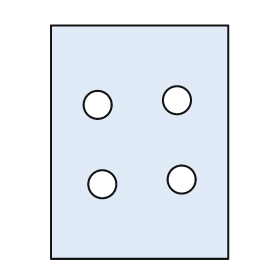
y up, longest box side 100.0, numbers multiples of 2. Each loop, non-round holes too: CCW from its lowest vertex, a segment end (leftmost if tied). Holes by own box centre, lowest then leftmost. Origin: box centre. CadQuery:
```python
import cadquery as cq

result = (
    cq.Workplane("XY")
    .moveTo(-38.0, -50.0)
    .lineTo(38.0, -50.0)
    .lineTo(38.0, 50.0)
    .lineTo(-38.0, 50.0)
    .close()
    .moveTo(-16.0, -18.0)
    .circle(6.0)
    .moveTo(18.0, -16.0)
    .circle(6.0)
    .moveTo(-18.0, 16.0)
    .circle(6.0)
    .moveTo(16.0, 18.0)
    .circle(6.0)
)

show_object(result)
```